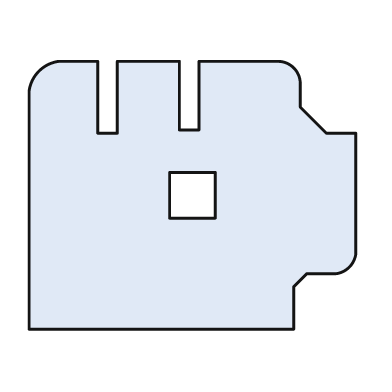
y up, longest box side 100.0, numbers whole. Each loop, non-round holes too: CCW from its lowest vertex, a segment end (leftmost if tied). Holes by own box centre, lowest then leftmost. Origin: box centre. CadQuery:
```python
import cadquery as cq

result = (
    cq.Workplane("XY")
    .moveTo(-50.0, -41.0)
    .lineTo(31.0, -41.0)
    .lineTo(31.0, -28.0)
    .lineTo(35.0, -24.0)
    .lineTo(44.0, -24.0)
    .threePointArc((48.0, -22.0), (50.0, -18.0))
    .lineTo(50.0, 19.0)
    .lineTo(41.0, 19.0)
    .lineTo(33.0, 27.0)
    .lineTo(33.0, 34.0)
    .threePointArc((31.0, 39.0), (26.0, 41.0))
    .lineTo(2.0, 41.0)
    .lineTo(2.0, 20.0)
    .lineTo(-4.0, 20.0)
    .lineTo(-4.0, 41.0)
    .lineTo(-23.0, 41.0)
    .lineTo(-23.0, 19.0)
    .lineTo(-29.0, 19.0)
    .lineTo(-29.0, 41.0)
    .lineTo(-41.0, 41.0)
    .threePointArc((-47.0, 38.0), (-50.0, 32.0))
    .close()
    .moveTo(-7.0, -7.0)
    .lineTo(7.0, -7.0)
    .lineTo(7.0, 7.0)
    .lineTo(-7.0, 7.0)
    .close()
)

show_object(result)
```